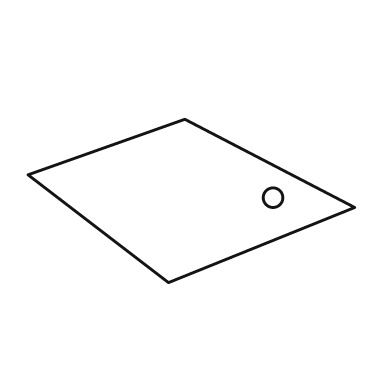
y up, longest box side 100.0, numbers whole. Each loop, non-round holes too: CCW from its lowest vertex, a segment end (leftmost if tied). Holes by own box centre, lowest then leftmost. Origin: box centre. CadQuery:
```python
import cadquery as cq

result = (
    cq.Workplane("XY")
    .moveTo(-7.0, -25.0)
    .lineTo(50.0, -2.0)
    .lineTo(-2.0, 25.0)
    .lineTo(-50.0, 8.0)
    .close()
    .moveTo(25.0, 1.0)
    .circle(3.0)
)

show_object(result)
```